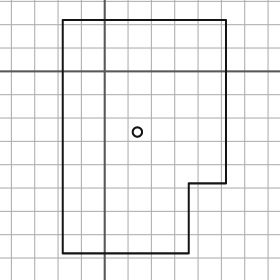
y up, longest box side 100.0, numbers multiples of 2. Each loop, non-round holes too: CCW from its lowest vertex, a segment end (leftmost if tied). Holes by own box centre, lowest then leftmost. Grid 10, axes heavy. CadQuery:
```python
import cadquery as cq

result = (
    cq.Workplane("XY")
    .moveTo(-18.0, -78.0)
    .lineTo(36.0, -78.0)
    .lineTo(36.0, -48.0)
    .lineTo(52.0, -48.0)
    .lineTo(52.0, 22.0)
    .lineTo(-18.0, 22.0)
    .close()
    .moveTo(14.0, -26.0)
    .circle(2.0)
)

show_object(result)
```